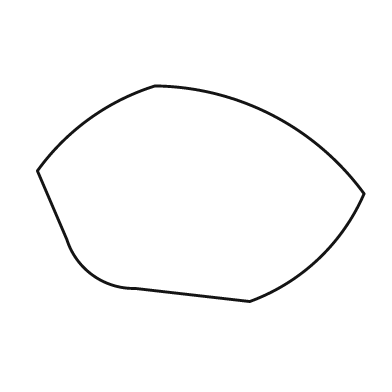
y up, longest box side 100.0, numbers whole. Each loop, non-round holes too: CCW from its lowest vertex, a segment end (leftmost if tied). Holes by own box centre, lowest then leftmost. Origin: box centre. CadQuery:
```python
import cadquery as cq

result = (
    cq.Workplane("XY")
    .moveTo(15.0, -33.0)
    .threePointArc((36.0, -20.0), (50.0, 0.0))
    .threePointArc((22.0, 24.0), (-14.0, 33.0))
    .threePointArc((-34.0, 23.0), (-50.0, 7.0))
    .lineTo(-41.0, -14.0)
    .threePointArc((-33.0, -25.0), (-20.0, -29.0))
    .close()
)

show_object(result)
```